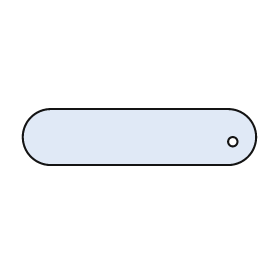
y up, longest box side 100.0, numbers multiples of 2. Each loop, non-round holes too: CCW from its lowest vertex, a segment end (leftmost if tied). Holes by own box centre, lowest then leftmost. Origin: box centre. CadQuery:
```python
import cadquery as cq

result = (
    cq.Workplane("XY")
    .moveTo(-38.0, -12.0)
    .lineTo(38.0, -12.0)
    .threePointArc((50.0, 0.0), (38.0, 12.0))
    .lineTo(-38.0, 12.0)
    .threePointArc((-50.0, 0.0), (-38.0, -12.0))
    .close()
    .moveTo(40.0, -2.0)
    .circle(2.0)
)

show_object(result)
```